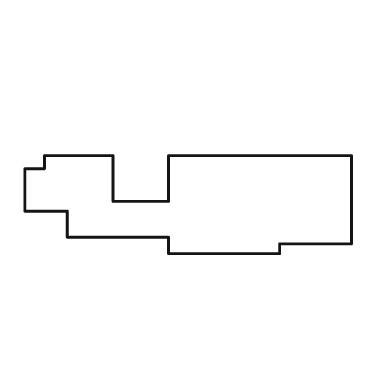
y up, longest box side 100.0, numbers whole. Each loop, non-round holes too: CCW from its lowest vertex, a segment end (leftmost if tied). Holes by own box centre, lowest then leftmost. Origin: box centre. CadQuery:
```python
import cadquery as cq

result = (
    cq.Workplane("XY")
    .moveTo(-6.0, -15.0)
    .lineTo(28.0, -15.0)
    .lineTo(28.0, -12.0)
    .lineTo(50.0, -12.0)
    .lineTo(50.0, 15.0)
    .lineTo(-6.0, 15.0)
    .lineTo(-6.0, 1.0)
    .lineTo(-23.0, 1.0)
    .lineTo(-23.0, 15.0)
    .lineTo(-44.0, 15.0)
    .lineTo(-44.0, 11.0)
    .lineTo(-50.0, 11.0)
    .lineTo(-50.0, -2.0)
    .lineTo(-37.0, -2.0)
    .lineTo(-37.0, -10.0)
    .lineTo(-6.0, -10.0)
    .close()
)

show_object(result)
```